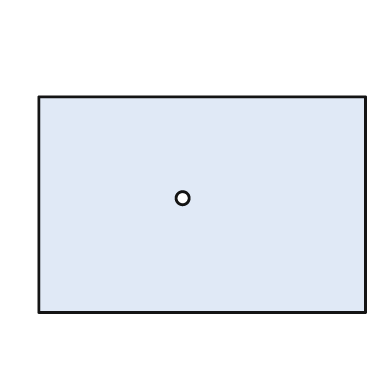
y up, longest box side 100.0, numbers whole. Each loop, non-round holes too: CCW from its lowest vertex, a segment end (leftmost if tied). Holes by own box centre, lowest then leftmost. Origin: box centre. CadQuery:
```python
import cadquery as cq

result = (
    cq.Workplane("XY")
    .moveTo(-50.0, -33.0)
    .lineTo(50.0, -33.0)
    .lineTo(50.0, 33.0)
    .lineTo(-50.0, 33.0)
    .close()
    .moveTo(-6.0, 2.0)
    .circle(2.0)
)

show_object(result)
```